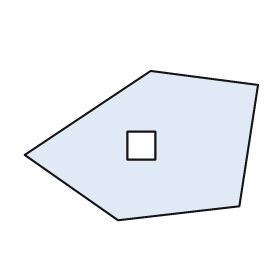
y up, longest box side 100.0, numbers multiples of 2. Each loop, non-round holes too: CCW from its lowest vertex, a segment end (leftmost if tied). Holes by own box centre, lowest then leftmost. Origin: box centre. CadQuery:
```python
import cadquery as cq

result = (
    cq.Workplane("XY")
    .moveTo(-10.0, -32.0)
    .lineTo(42.0, -26.0)
    .lineTo(50.0, 26.0)
    .lineTo(4.0, 32.0)
    .lineTo(-50.0, -4.0)
    .close()
    .moveTo(-6.0, -6.0)
    .lineTo(6.0, -6.0)
    .lineTo(6.0, 6.0)
    .lineTo(-6.0, 6.0)
    .close()
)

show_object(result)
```